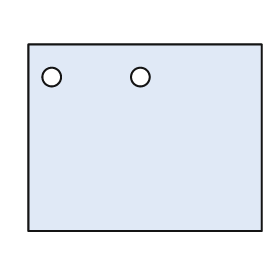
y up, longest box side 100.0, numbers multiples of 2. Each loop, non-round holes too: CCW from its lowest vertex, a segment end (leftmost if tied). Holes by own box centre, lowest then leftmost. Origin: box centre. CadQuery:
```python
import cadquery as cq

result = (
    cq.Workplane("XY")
    .moveTo(-50.0, -40.0)
    .lineTo(50.0, -40.0)
    .lineTo(50.0, 40.0)
    .lineTo(-50.0, 40.0)
    .close()
    .moveTo(-40.0, 26.0)
    .circle(4.0)
    .moveTo(-2.0, 26.0)
    .circle(4.0)
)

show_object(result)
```